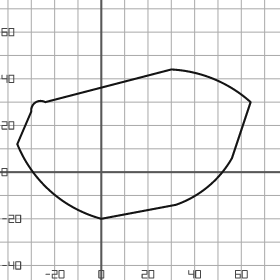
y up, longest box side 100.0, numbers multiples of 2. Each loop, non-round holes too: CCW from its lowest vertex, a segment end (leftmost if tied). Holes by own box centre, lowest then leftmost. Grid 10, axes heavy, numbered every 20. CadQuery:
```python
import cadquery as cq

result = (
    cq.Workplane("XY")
    .moveTo(0.0, -20.0)
    .lineTo(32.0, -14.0)
    .threePointArc((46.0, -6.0), (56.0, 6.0))
    .lineTo(64.0, 30.0)
    .threePointArc((48.0, 40.0), (30.0, 44.0))
    .lineTo(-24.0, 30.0)
    .threePointArc((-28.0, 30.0), (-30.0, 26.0))
    .lineTo(-36.0, 12.0)
    .threePointArc((-22.0, -8.0), (0.0, -20.0))
    .close()
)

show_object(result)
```